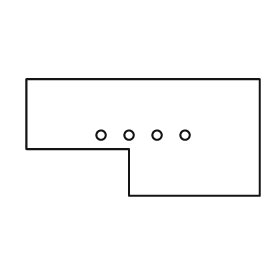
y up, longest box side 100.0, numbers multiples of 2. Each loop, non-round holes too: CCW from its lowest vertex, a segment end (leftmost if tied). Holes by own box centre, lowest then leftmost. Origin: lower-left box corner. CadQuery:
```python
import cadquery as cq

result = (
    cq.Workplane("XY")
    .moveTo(44.0, 0.0)
    .lineTo(100.0, 0.0)
    .lineTo(100.0, 50.0)
    .lineTo(0.0, 50.0)
    .lineTo(0.0, 20.0)
    .lineTo(44.0, 20.0)
    .close()
    .moveTo(32.0, 26.0)
    .circle(2.0)
    .moveTo(44.0, 26.0)
    .circle(2.0)
    .moveTo(56.0, 26.0)
    .circle(2.0)
    .moveTo(68.0, 26.0)
    .circle(2.0)
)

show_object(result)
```